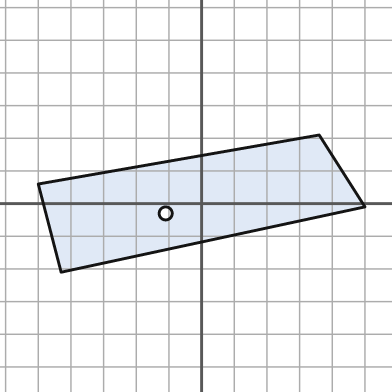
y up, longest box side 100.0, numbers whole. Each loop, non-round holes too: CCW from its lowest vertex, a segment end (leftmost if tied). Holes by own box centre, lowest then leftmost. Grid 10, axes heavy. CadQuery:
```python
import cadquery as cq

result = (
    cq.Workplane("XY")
    .moveTo(-43.0, -21.0)
    .lineTo(50.0, -1.0)
    .lineTo(36.0, 21.0)
    .lineTo(-50.0, 6.0)
    .close()
    .moveTo(-11.0, -3.0)
    .circle(2.0)
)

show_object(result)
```